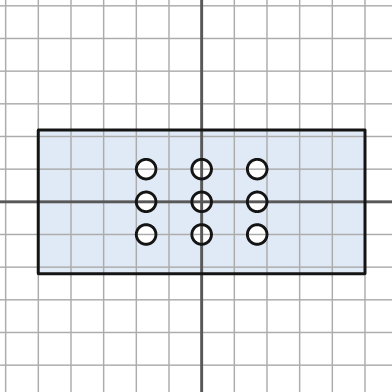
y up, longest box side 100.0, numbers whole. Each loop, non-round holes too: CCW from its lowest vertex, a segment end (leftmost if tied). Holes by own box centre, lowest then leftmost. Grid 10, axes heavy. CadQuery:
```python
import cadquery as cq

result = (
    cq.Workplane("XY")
    .moveTo(-50.0, -22.0)
    .lineTo(50.0, -22.0)
    .lineTo(50.0, 22.0)
    .lineTo(-50.0, 22.0)
    .close()
    .moveTo(-17.0, -10.0)
    .circle(3.0)
    .moveTo(0.0, -10.0)
    .circle(3.0)
    .moveTo(17.0, -10.0)
    .circle(3.0)
    .moveTo(-17.0, 0.0)
    .circle(3.0)
    .moveTo(0.0, 0.0)
    .circle(3.0)
    .moveTo(17.0, 0.0)
    .circle(3.0)
    .moveTo(-17.0, 10.0)
    .circle(3.0)
    .moveTo(0.0, 10.0)
    .circle(3.0)
    .moveTo(17.0, 10.0)
    .circle(3.0)
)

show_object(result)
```